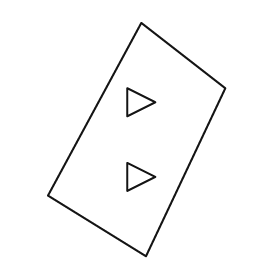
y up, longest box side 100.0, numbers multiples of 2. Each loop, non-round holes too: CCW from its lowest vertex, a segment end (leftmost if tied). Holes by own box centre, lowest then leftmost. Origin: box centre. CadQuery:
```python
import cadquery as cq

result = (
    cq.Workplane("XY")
    .moveTo(4.0, -50.0)
    .lineTo(38.0, 22.0)
    .lineTo(2.0, 50.0)
    .lineTo(-38.0, -24.0)
    .close()
    .moveTo(-4.0, -22.0)
    .lineTo(8.0, -16.0)
    .lineTo(-4.0, -10.0)
    .close()
    .moveTo(-4.0, 10.0)
    .lineTo(8.0, 16.0)
    .lineTo(-4.0, 22.0)
    .close()
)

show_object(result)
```